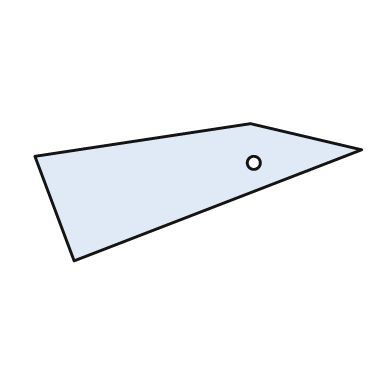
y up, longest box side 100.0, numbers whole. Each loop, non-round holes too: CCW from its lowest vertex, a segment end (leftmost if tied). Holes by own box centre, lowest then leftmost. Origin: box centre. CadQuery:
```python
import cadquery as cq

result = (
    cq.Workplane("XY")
    .moveTo(-38.0, -21.0)
    .lineTo(50.0, 13.0)
    .lineTo(16.0, 21.0)
    .lineTo(-50.0, 11.0)
    .close()
    .moveTo(17.0, 9.0)
    .circle(2.0)
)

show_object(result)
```